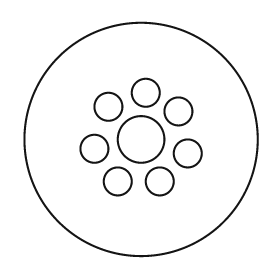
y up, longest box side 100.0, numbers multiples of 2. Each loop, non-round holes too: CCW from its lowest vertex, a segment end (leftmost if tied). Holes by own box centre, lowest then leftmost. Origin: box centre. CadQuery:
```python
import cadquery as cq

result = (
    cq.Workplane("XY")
    .moveTo(0.0, 0.0)
    .circle(50.0)
    .moveTo(-10.0, -18.0)
    .circle(6.0)
    .moveTo(8.0, -18.0)
    .circle(6.0)
    .moveTo(20.0, -6.0)
    .circle(6.0)
    .moveTo(-20.0, -4.0)
    .circle(6.0)
    .moveTo(0.0, 0.0)
    .circle(10.0)
    .moveTo(16.0, 12.0)
    .circle(6.0)
    .moveTo(-14.0, 14.0)
    .circle(6.0)
    .moveTo(2.0, 20.0)
    .circle(6.0)
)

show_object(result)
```